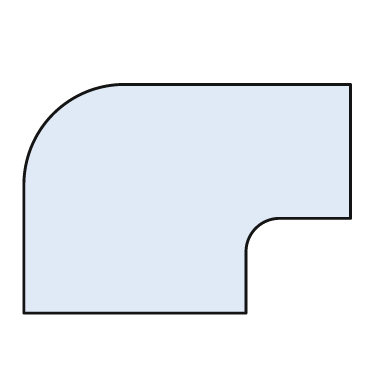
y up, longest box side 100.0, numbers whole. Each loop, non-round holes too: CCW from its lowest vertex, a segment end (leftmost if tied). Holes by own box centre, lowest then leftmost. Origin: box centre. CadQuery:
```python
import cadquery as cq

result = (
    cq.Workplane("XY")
    .moveTo(-50.0, -35.0)
    .lineTo(18.0, -35.0)
    .lineTo(18.0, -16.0)
    .threePointArc((21.0, -9.0), (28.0, -6.0))
    .lineTo(50.0, -6.0)
    .lineTo(50.0, 35.0)
    .lineTo(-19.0, 35.0)
    .threePointArc((-41.0, 26.0), (-50.0, 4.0))
    .close()
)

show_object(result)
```